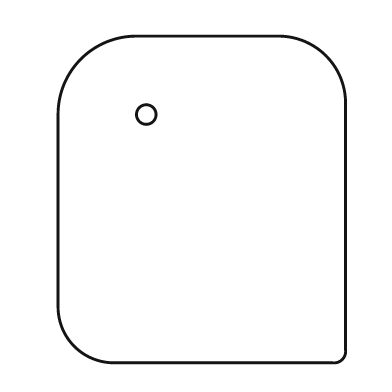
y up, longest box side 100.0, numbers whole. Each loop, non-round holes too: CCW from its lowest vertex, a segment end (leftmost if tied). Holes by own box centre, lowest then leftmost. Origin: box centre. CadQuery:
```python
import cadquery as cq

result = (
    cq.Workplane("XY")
    .moveTo(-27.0, -50.0)
    .lineTo(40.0, -50.0)
    .threePointArc((43.0, -49.0), (44.0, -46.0))
    .lineTo(44.0, 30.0)
    .threePointArc((38.0, 44.0), (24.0, 50.0))
    .lineTo(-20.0, 50.0)
    .threePointArc((-37.0, 43.0), (-44.0, 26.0))
    .lineTo(-44.0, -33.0)
    .threePointArc((-39.0, -45.0), (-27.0, -50.0))
    .close()
    .moveTo(-17.0, 26.0)
    .circle(3.0)
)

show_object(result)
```